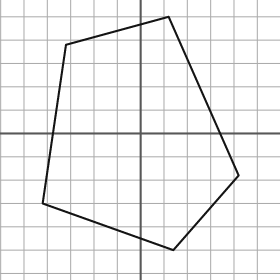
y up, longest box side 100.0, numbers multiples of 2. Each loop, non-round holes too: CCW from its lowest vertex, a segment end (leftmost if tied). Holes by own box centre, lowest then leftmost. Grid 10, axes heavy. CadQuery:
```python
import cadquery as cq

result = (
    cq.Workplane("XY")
    .moveTo(14.0, -50.0)
    .lineTo(42.0, -18.0)
    .lineTo(12.0, 50.0)
    .lineTo(-32.0, 38.0)
    .lineTo(-42.0, -30.0)
    .close()
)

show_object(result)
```